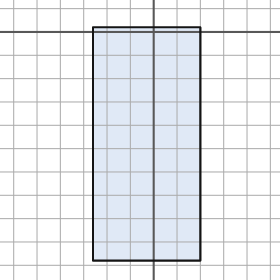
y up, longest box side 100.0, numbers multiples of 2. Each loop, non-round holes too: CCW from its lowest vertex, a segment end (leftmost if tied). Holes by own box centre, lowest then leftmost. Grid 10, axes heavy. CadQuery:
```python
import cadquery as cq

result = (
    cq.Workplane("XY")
    .moveTo(-26.0, -98.0)
    .lineTo(20.0, -98.0)
    .lineTo(20.0, 2.0)
    .lineTo(-26.0, 2.0)
    .close()
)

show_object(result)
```